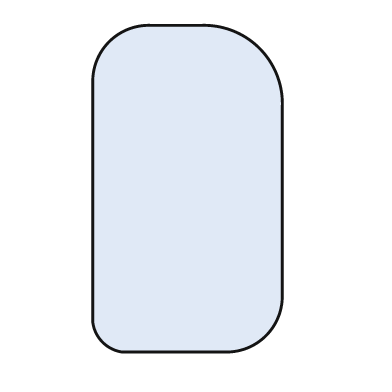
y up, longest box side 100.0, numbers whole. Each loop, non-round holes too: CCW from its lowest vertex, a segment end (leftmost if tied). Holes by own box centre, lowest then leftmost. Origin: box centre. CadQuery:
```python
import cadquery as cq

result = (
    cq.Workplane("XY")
    .moveTo(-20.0, -50.0)
    .lineTo(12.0, -50.0)
    .threePointArc((24.0, -45.0), (29.0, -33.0))
    .lineTo(29.0, 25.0)
    .threePointArc((22.0, 43.0), (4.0, 50.0))
    .lineTo(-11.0, 50.0)
    .threePointArc((-24.0, 45.0), (-29.0, 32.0))
    .lineTo(-29.0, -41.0)
    .threePointArc((-26.0, -47.0), (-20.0, -50.0))
    .close()
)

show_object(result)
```